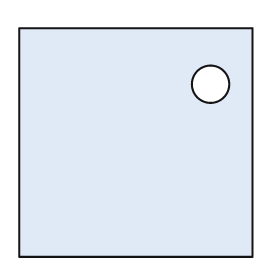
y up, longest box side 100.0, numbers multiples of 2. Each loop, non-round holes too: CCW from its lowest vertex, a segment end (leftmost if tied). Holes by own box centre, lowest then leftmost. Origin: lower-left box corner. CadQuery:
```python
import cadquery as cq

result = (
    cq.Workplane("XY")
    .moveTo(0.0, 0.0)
    .lineTo(100.0, 0.0)
    .lineTo(100.0, 98.0)
    .lineTo(0.0, 98.0)
    .close()
    .moveTo(82.0, 74.0)
    .circle(8.0)
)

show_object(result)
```